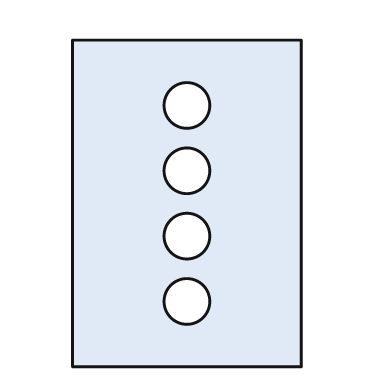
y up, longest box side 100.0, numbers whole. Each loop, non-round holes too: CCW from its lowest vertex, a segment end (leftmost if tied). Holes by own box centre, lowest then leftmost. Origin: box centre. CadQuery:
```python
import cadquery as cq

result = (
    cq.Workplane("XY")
    .moveTo(-35.0, -50.0)
    .lineTo(35.0, -50.0)
    .lineTo(35.0, 50.0)
    .lineTo(-35.0, 50.0)
    .close()
    .moveTo(0.0, -30.0)
    .circle(7.0)
    .moveTo(0.0, -10.0)
    .circle(7.0)
    .moveTo(0.0, 10.0)
    .circle(7.0)
    .moveTo(0.0, 30.0)
    .circle(7.0)
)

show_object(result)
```